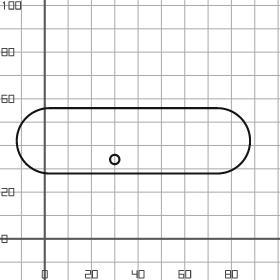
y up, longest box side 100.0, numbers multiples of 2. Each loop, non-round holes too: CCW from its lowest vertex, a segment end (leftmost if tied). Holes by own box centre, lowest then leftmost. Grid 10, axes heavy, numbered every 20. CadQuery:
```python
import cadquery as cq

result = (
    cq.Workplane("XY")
    .moveTo(2.0, 28.0)
    .lineTo(74.0, 28.0)
    .threePointArc((88.0, 42.0), (74.0, 56.0))
    .lineTo(2.0, 56.0)
    .threePointArc((-12.0, 42.0), (2.0, 28.0))
    .close()
    .moveTo(30.0, 34.0)
    .circle(2.0)
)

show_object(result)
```